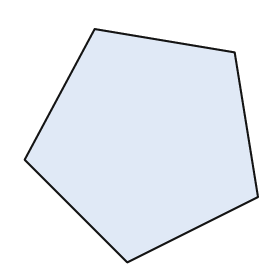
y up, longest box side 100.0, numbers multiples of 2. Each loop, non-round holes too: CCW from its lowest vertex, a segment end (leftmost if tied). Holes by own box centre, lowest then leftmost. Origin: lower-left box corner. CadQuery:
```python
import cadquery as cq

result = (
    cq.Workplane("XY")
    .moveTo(44.0, 0.0)
    .lineTo(100.0, 28.0)
    .lineTo(90.0, 90.0)
    .lineTo(30.0, 100.0)
    .lineTo(0.0, 44.0)
    .close()
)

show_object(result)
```